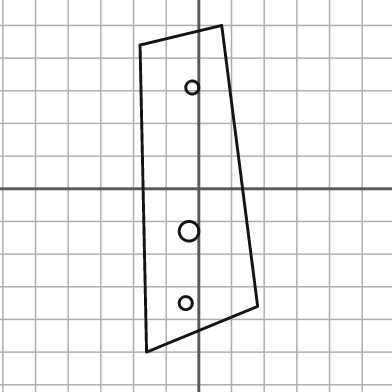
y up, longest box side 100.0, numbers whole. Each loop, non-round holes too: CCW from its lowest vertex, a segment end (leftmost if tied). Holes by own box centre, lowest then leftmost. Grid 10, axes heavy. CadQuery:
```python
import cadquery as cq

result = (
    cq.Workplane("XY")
    .moveTo(-16.0, -50.0)
    .lineTo(18.0, -36.0)
    .lineTo(7.0, 50.0)
    .lineTo(-18.0, 44.0)
    .close()
    .moveTo(-4.0, -35.0)
    .circle(2.0)
    .moveTo(-3.0, -13.0)
    .circle(3.0)
    .moveTo(-2.0, 31.0)
    .circle(2.0)
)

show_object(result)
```